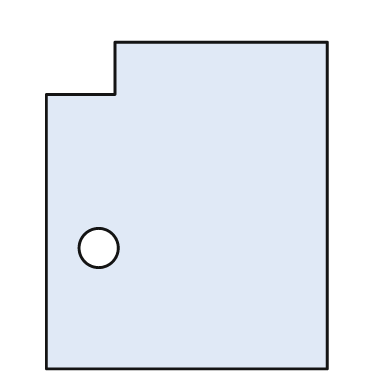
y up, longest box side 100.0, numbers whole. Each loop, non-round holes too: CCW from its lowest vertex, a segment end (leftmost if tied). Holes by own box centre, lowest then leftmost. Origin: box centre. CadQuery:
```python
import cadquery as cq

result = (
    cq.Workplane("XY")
    .moveTo(-43.0, -50.0)
    .lineTo(43.0, -50.0)
    .lineTo(43.0, 50.0)
    .lineTo(-22.0, 50.0)
    .lineTo(-22.0, 34.0)
    .lineTo(-43.0, 34.0)
    .close()
    .moveTo(-27.0, -13.0)
    .circle(6.0)
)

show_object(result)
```